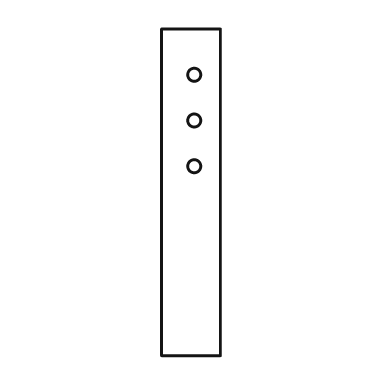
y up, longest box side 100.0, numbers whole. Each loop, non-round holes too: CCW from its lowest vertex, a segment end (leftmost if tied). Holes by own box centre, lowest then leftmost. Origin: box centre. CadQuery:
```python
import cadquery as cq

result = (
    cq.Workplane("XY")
    .moveTo(-9.0, -50.0)
    .lineTo(9.0, -50.0)
    .lineTo(9.0, 50.0)
    .lineTo(-9.0, 50.0)
    .close()
    .moveTo(1.0, 8.0)
    .circle(2.0)
    .moveTo(1.0, 22.0)
    .circle(2.0)
    .moveTo(1.0, 36.0)
    .circle(2.0)
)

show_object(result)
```